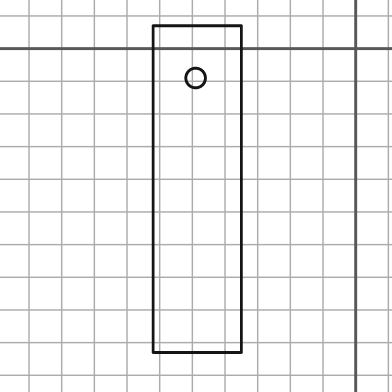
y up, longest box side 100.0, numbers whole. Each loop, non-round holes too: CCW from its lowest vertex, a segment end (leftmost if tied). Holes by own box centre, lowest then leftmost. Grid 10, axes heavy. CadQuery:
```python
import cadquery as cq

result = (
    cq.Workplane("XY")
    .moveTo(-62.0, -93.0)
    .lineTo(-35.0, -93.0)
    .lineTo(-35.0, 7.0)
    .lineTo(-62.0, 7.0)
    .close()
    .moveTo(-49.0, -9.0)
    .circle(3.0)
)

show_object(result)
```